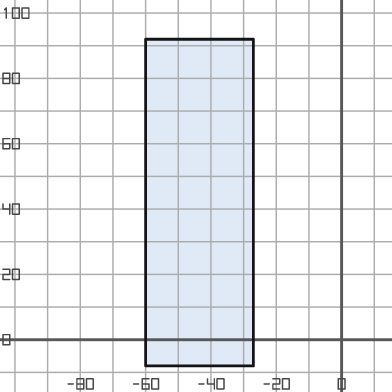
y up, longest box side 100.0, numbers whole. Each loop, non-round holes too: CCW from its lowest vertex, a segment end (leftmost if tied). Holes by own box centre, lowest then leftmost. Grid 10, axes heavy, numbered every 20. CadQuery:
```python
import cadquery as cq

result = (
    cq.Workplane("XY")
    .moveTo(-60.0, -8.0)
    .lineTo(-27.0, -8.0)
    .lineTo(-27.0, 92.0)
    .lineTo(-60.0, 92.0)
    .close()
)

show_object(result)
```